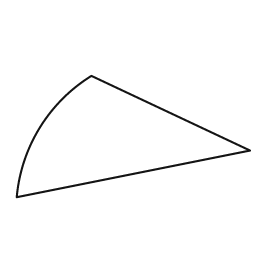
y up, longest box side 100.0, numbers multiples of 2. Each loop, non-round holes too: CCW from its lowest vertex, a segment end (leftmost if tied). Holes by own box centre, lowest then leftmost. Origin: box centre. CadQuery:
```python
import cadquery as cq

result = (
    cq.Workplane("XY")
    .moveTo(-50.0, -26.0)
    .lineTo(50.0, -6.0)
    .lineTo(-18.0, 26.0)
    .threePointArc((-40.0, 4.0), (-50.0, -26.0))
    .close()
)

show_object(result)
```